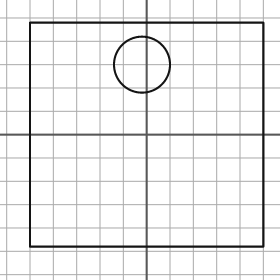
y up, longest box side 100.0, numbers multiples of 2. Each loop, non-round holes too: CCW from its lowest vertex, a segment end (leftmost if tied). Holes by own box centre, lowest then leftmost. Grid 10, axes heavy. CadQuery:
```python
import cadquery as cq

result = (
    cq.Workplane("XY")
    .moveTo(-50.0, -48.0)
    .lineTo(50.0, -48.0)
    .lineTo(50.0, 48.0)
    .lineTo(-50.0, 48.0)
    .close()
    .moveTo(-2.0, 30.0)
    .circle(12.0)
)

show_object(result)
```